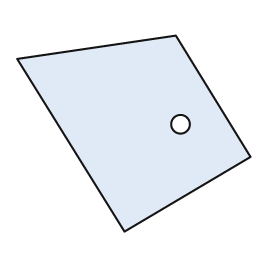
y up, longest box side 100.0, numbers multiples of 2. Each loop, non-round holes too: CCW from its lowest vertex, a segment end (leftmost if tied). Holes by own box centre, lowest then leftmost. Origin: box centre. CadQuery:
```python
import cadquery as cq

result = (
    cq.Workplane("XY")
    .moveTo(-4.0, -42.0)
    .lineTo(50.0, -10.0)
    .lineTo(18.0, 42.0)
    .lineTo(-50.0, 32.0)
    .close()
    .moveTo(20.0, 4.0)
    .circle(4.0)
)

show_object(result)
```